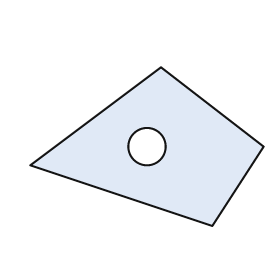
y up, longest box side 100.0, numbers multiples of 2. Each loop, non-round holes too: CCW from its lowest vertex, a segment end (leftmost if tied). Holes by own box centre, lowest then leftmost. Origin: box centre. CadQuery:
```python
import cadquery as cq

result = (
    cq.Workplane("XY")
    .moveTo(28.0, -34.0)
    .lineTo(50.0, 0.0)
    .lineTo(6.0, 34.0)
    .lineTo(-50.0, -8.0)
    .close()
    .moveTo(0.0, 0.0)
    .circle(8.0)
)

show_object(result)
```